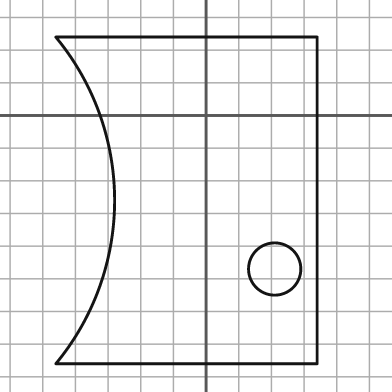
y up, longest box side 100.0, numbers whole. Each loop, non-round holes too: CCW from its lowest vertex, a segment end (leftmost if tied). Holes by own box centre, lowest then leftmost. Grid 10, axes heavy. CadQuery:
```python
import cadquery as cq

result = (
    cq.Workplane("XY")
    .moveTo(-46.0, -76.0)
    .lineTo(34.0, -76.0)
    .lineTo(34.0, 24.0)
    .lineTo(-46.0, 24.0)
    .threePointArc((-28.0, -26.0), (-46.0, -76.0))
    .close()
    .moveTo(21.0, -47.0)
    .circle(8.0)
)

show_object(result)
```